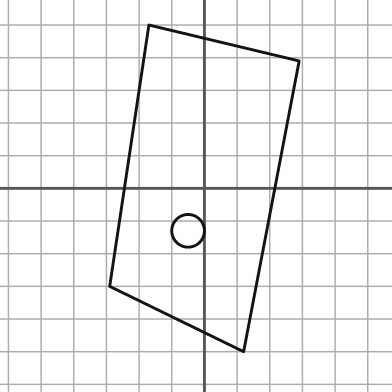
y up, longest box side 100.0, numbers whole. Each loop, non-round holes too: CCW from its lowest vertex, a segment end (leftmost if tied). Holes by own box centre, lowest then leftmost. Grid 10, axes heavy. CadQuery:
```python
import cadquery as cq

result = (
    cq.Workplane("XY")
    .moveTo(12.0, -50.0)
    .lineTo(29.0, 39.0)
    .lineTo(-17.0, 50.0)
    .lineTo(-29.0, -30.0)
    .close()
    .moveTo(-5.0, -13.0)
    .circle(5.0)
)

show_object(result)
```